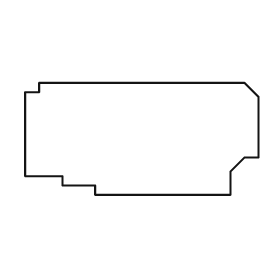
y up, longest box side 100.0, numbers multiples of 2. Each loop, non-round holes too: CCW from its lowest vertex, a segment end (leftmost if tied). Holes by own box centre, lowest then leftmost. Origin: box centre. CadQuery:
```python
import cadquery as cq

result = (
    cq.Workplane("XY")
    .moveTo(-20.0, -24.0)
    .lineTo(38.0, -24.0)
    .lineTo(38.0, -14.0)
    .lineTo(44.0, -8.0)
    .lineTo(50.0, -8.0)
    .lineTo(50.0, 18.0)
    .lineTo(44.0, 24.0)
    .lineTo(-44.0, 24.0)
    .lineTo(-44.0, 20.0)
    .lineTo(-50.0, 20.0)
    .lineTo(-50.0, -16.0)
    .lineTo(-34.0, -16.0)
    .lineTo(-34.0, -20.0)
    .lineTo(-20.0, -20.0)
    .close()
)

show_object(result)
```